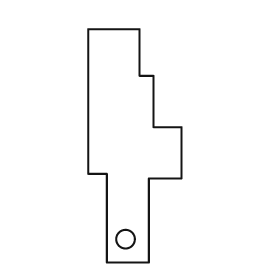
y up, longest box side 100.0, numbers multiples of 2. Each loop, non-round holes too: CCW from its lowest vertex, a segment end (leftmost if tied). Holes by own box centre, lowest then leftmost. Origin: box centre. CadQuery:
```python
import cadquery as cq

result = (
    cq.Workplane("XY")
    .moveTo(-12.0, -50.0)
    .lineTo(6.0, -50.0)
    .lineTo(6.0, -14.0)
    .lineTo(20.0, -14.0)
    .lineTo(20.0, 8.0)
    .lineTo(8.0, 8.0)
    .lineTo(8.0, 30.0)
    .lineTo(2.0, 30.0)
    .lineTo(2.0, 50.0)
    .lineTo(-20.0, 50.0)
    .lineTo(-20.0, -12.0)
    .lineTo(-12.0, -12.0)
    .close()
    .moveTo(-4.0, -40.0)
    .circle(4.0)
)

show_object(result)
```